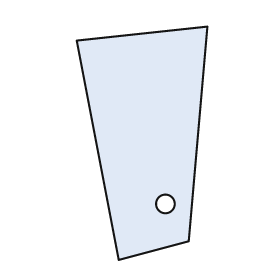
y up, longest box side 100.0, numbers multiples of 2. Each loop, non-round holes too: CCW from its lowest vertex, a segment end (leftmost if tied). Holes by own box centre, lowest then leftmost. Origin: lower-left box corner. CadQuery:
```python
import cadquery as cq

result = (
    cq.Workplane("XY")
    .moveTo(18.0, 0.0)
    .lineTo(48.0, 8.0)
    .lineTo(56.0, 100.0)
    .lineTo(0.0, 94.0)
    .close()
    .moveTo(38.0, 24.0)
    .circle(4.0)
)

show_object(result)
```